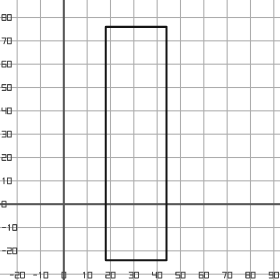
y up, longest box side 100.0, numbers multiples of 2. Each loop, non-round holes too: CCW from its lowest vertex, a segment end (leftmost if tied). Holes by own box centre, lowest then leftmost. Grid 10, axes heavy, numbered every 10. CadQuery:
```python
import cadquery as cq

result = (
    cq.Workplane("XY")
    .moveTo(18.0, -24.0)
    .lineTo(44.0, -24.0)
    .lineTo(44.0, 76.0)
    .lineTo(18.0, 76.0)
    .close()
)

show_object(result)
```